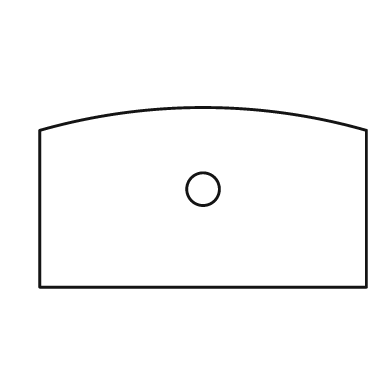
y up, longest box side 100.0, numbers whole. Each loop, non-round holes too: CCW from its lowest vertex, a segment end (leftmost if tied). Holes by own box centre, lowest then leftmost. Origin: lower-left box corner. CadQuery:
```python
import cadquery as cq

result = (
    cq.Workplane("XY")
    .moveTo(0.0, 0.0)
    .lineTo(100.0, 0.0)
    .lineTo(100.0, 48.0)
    .threePointArc((50.0, 55.0), (0.0, 48.0))
    .close()
    .moveTo(50.0, 30.0)
    .circle(5.0)
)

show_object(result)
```